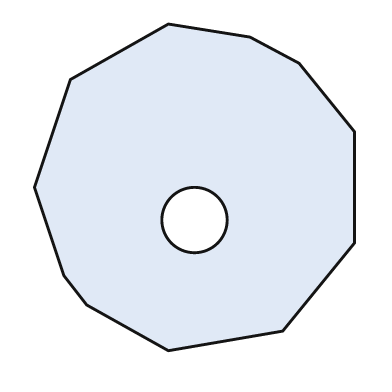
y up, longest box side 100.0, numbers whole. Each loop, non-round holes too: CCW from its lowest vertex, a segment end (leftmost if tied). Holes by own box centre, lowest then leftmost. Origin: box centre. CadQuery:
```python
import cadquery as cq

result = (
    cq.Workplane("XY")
    .moveTo(-8.0, -50.0)
    .lineTo(27.0, -44.0)
    .lineTo(49.0, -17.0)
    .lineTo(49.0, 17.0)
    .lineTo(32.0, 38.0)
    .lineTo(17.0, 46.0)
    .lineTo(-8.0, 50.0)
    .lineTo(-38.0, 33.0)
    .lineTo(-49.0, 0.0)
    .lineTo(-40.0, -27.0)
    .lineTo(-33.0, -36.0)
    .close()
    .moveTo(0.0, -10.0)
    .circle(10.0)
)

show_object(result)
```